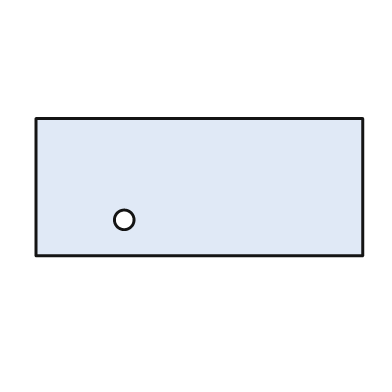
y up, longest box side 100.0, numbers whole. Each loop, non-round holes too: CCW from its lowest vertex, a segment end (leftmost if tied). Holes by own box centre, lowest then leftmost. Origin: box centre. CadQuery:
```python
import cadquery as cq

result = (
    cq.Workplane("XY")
    .moveTo(-50.0, -21.0)
    .lineTo(50.0, -21.0)
    .lineTo(50.0, 21.0)
    .lineTo(-50.0, 21.0)
    .close()
    .moveTo(-23.0, -10.0)
    .circle(3.0)
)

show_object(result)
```